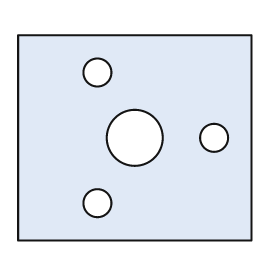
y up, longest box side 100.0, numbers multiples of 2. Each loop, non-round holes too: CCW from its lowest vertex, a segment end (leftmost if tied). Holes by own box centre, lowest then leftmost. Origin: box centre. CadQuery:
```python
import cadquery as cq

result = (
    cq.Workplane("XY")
    .moveTo(-50.0, -44.0)
    .lineTo(50.0, -44.0)
    .lineTo(50.0, 44.0)
    .lineTo(-50.0, 44.0)
    .close()
    .moveTo(-16.0, -28.0)
    .circle(6.0)
    .moveTo(0.0, 0.0)
    .circle(12.0)
    .moveTo(34.0, 0.0)
    .circle(6.0)
    .moveTo(-16.0, 28.0)
    .circle(6.0)
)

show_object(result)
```